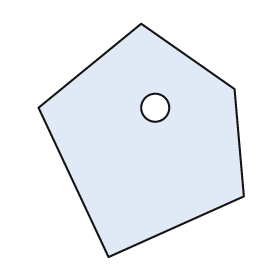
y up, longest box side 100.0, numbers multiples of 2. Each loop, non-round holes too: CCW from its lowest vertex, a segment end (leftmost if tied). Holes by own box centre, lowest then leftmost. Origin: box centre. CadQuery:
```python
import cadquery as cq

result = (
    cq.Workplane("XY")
    .moveTo(-14.0, -50.0)
    .lineTo(44.0, -24.0)
    .lineTo(40.0, 22.0)
    .lineTo(0.0, 50.0)
    .lineTo(-44.0, 14.0)
    .close()
    .moveTo(6.0, 14.0)
    .circle(6.0)
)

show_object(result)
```